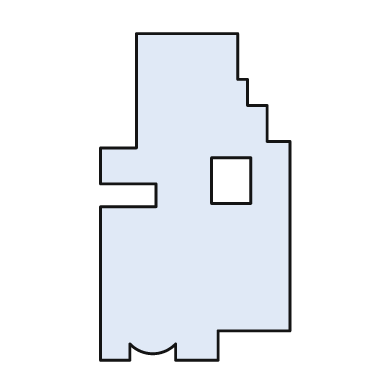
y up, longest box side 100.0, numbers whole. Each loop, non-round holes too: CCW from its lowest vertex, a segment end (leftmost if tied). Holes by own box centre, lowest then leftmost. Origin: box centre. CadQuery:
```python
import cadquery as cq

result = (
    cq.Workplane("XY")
    .moveTo(-29.0, -50.0)
    .lineTo(-20.0, -50.0)
    .lineTo(-20.0, -45.0)
    .threePointArc((-13.0, -48.0), (-6.0, -45.0))
    .lineTo(-6.0, -50.0)
    .lineTo(7.0, -50.0)
    .lineTo(7.0, -41.0)
    .lineTo(29.0, -41.0)
    .lineTo(29.0, 17.0)
    .lineTo(22.0, 17.0)
    .lineTo(22.0, 28.0)
    .lineTo(16.0, 28.0)
    .lineTo(16.0, 36.0)
    .lineTo(13.0, 36.0)
    .lineTo(13.0, 50.0)
    .lineTo(-18.0, 50.0)
    .lineTo(-18.0, 15.0)
    .lineTo(-29.0, 15.0)
    .lineTo(-29.0, 4.0)
    .lineTo(-12.0, 4.0)
    .lineTo(-12.0, -3.0)
    .lineTo(-29.0, -3.0)
    .close()
    .moveTo(5.0, -2.0)
    .lineTo(17.0, -2.0)
    .lineTo(17.0, 12.0)
    .lineTo(5.0, 12.0)
    .close()
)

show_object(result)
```